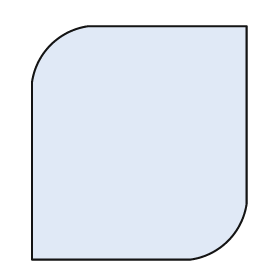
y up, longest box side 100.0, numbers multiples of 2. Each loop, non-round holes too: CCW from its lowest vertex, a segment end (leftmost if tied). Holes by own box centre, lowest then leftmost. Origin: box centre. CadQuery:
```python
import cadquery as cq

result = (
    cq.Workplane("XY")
    .moveTo(-46.0, -50.0)
    .lineTo(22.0, -50.0)
    .threePointArc((38.0, -42.0), (46.0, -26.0))
    .lineTo(46.0, 50.0)
    .lineTo(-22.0, 50.0)
    .threePointArc((-38.0, 42.0), (-46.0, 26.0))
    .close()
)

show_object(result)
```